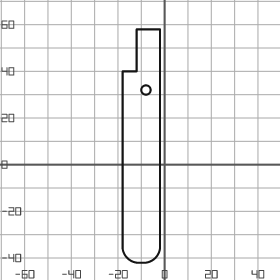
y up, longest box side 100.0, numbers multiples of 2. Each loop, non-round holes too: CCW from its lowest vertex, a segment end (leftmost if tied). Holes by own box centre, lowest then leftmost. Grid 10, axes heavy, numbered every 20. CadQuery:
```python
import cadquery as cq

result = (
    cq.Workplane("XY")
    .moveTo(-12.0, -42.0)
    .lineTo(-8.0, -42.0)
    .threePointArc((-4.0, -40.0), (-2.0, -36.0))
    .lineTo(-2.0, 58.0)
    .lineTo(-12.0, 58.0)
    .lineTo(-12.0, 40.0)
    .lineTo(-18.0, 40.0)
    .lineTo(-18.0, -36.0)
    .threePointArc((-16.0, -40.0), (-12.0, -42.0))
    .close()
    .moveTo(-8.0, 32.0)
    .circle(2.0)
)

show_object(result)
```